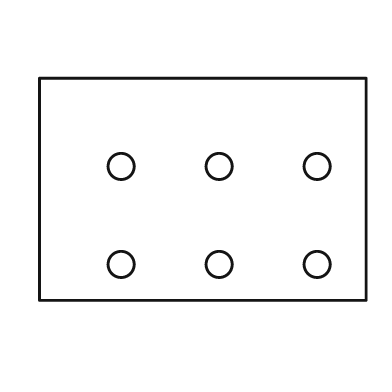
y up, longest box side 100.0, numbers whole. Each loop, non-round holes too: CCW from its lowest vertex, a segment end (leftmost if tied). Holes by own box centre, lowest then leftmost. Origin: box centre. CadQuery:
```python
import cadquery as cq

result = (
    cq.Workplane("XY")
    .moveTo(-50.0, -34.0)
    .lineTo(50.0, -34.0)
    .lineTo(50.0, 34.0)
    .lineTo(-50.0, 34.0)
    .close()
    .moveTo(-25.0, -23.0)
    .circle(4.0)
    .moveTo(5.0, -23.0)
    .circle(4.0)
    .moveTo(35.0, -23.0)
    .circle(4.0)
    .moveTo(-25.0, 7.0)
    .circle(4.0)
    .moveTo(5.0, 7.0)
    .circle(4.0)
    .moveTo(35.0, 7.0)
    .circle(4.0)
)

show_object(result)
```